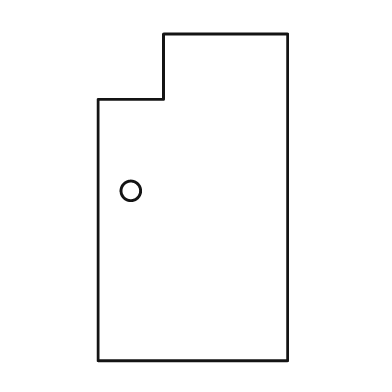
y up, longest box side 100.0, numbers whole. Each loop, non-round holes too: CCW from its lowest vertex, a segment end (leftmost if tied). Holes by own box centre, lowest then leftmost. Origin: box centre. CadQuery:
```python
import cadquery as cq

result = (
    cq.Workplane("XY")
    .moveTo(-29.0, -50.0)
    .lineTo(29.0, -50.0)
    .lineTo(29.0, 50.0)
    .lineTo(-9.0, 50.0)
    .lineTo(-9.0, 30.0)
    .lineTo(-29.0, 30.0)
    .close()
    .moveTo(-19.0, 2.0)
    .circle(3.0)
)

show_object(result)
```